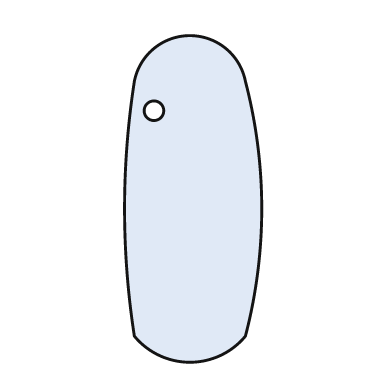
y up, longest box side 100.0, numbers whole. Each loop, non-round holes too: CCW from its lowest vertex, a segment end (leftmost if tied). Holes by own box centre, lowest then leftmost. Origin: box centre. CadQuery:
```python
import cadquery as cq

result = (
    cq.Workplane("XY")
    .moveTo(-18.0, -42.0)
    .threePointArc((-1.0, -50.0), (16.0, -42.0))
    .threePointArc((21.0, -3.0), (16.0, 36.0))
    .threePointArc((-1.0, 50.0), (-18.0, 36.0))
    .threePointArc((-21.0, -3.0), (-18.0, -42.0))
    .close()
    .moveTo(-12.0, 27.0)
    .circle(3.0)
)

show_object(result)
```